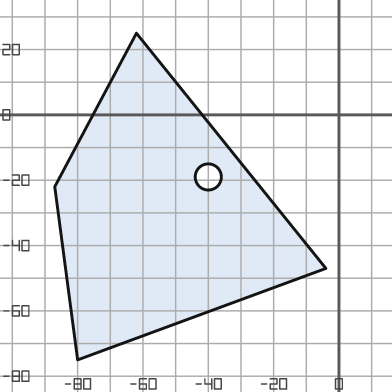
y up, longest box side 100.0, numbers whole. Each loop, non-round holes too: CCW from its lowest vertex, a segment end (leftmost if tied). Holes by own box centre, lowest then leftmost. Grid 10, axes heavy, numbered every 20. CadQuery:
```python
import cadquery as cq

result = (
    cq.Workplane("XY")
    .moveTo(-80.0, -75.0)
    .lineTo(-4.0, -47.0)
    .lineTo(-62.0, 25.0)
    .lineTo(-87.0, -22.0)
    .close()
    .moveTo(-40.0, -19.0)
    .circle(4.0)
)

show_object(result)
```